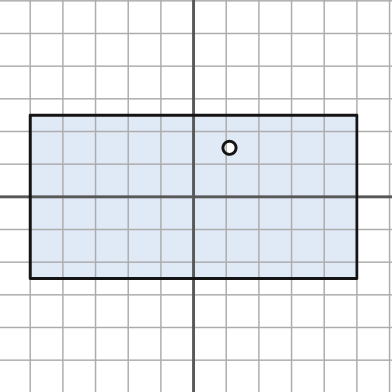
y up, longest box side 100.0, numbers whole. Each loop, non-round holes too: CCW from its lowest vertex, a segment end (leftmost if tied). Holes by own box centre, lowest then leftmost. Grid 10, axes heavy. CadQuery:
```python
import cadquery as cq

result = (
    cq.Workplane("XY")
    .moveTo(-50.0, -25.0)
    .lineTo(50.0, -25.0)
    .lineTo(50.0, 25.0)
    .lineTo(-50.0, 25.0)
    .close()
    .moveTo(11.0, 15.0)
    .circle(2.0)
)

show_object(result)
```